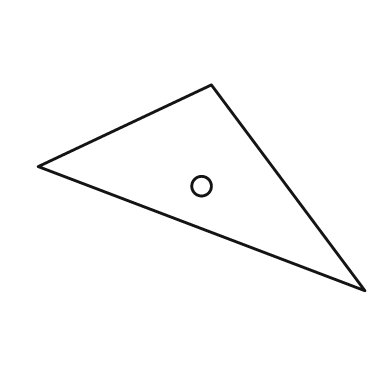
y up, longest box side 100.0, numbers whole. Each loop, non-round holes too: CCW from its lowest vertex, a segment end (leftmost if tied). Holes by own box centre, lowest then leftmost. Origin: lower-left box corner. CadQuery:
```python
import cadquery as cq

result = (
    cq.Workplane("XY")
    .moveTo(100.0, 0.0)
    .lineTo(53.0, 63.0)
    .lineTo(0.0, 38.0)
    .close()
    .moveTo(50.0, 32.0)
    .circle(3.0)
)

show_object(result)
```